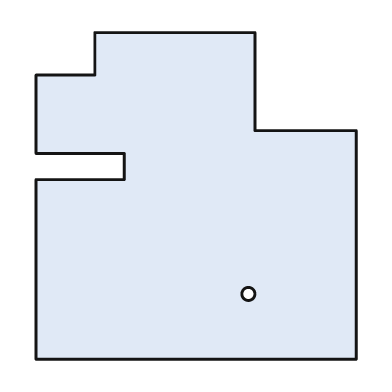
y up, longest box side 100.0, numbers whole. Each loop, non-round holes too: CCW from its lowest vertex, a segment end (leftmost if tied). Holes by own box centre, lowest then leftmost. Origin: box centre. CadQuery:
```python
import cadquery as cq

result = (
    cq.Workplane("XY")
    .moveTo(-49.0, -50.0)
    .lineTo(49.0, -50.0)
    .lineTo(49.0, 20.0)
    .lineTo(18.0, 20.0)
    .lineTo(18.0, 50.0)
    .lineTo(-31.0, 50.0)
    .lineTo(-31.0, 37.0)
    .lineTo(-49.0, 37.0)
    .lineTo(-49.0, 13.0)
    .lineTo(-22.0, 13.0)
    .lineTo(-22.0, 5.0)
    .lineTo(-49.0, 5.0)
    .close()
    .moveTo(16.0, -30.0)
    .circle(2.0)
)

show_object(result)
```